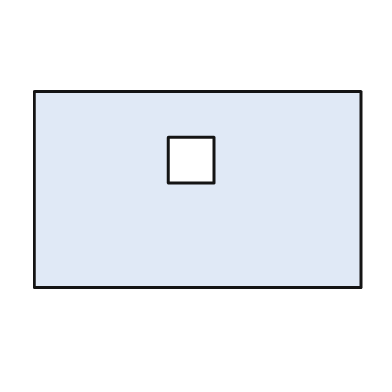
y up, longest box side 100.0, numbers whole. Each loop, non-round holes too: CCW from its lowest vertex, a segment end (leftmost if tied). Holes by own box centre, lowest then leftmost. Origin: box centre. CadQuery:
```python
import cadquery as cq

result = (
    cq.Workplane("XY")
    .moveTo(-50.0, -30.0)
    .lineTo(50.0, -30.0)
    .lineTo(50.0, 30.0)
    .lineTo(-50.0, 30.0)
    .close()
    .moveTo(-9.0, 2.0)
    .lineTo(5.0, 2.0)
    .lineTo(5.0, 16.0)
    .lineTo(-9.0, 16.0)
    .close()
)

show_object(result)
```